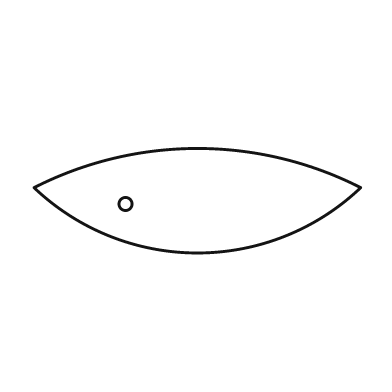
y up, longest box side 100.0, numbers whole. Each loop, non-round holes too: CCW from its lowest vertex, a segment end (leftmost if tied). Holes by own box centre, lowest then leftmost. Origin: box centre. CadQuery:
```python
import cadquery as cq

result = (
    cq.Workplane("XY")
    .moveTo(-50.0, 4.0)
    .threePointArc((0.0, -16.0), (50.0, 4.0))
    .threePointArc((0.0, 16.0), (-50.0, 4.0))
    .close()
    .moveTo(-22.0, -1.0)
    .circle(2.0)
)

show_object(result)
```